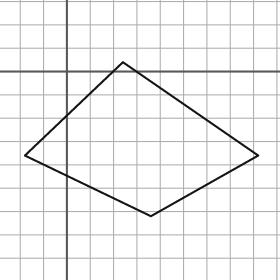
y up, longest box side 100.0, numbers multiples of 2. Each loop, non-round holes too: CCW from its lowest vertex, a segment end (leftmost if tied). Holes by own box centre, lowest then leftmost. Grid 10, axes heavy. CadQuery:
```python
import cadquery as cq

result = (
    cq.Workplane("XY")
    .moveTo(36.0, -62.0)
    .lineTo(82.0, -36.0)
    .lineTo(24.0, 4.0)
    .lineTo(-18.0, -36.0)
    .close()
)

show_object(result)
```